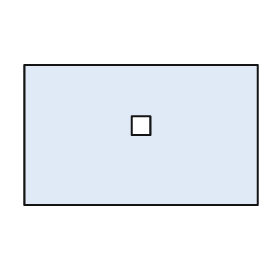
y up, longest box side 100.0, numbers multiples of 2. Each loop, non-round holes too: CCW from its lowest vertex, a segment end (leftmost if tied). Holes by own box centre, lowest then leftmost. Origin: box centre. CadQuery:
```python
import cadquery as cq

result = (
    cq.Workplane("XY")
    .moveTo(-50.0, -30.0)
    .lineTo(50.0, -30.0)
    .lineTo(50.0, 30.0)
    .lineTo(-50.0, 30.0)
    .close()
    .moveTo(-4.0, 0.0)
    .lineTo(4.0, 0.0)
    .lineTo(4.0, 8.0)
    .lineTo(-4.0, 8.0)
    .close()
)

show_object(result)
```